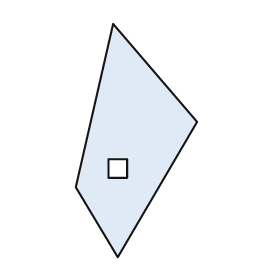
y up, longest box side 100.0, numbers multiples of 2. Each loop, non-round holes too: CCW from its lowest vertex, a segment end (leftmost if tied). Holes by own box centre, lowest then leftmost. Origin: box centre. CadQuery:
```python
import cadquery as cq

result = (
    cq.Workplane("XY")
    .moveTo(-8.0, -50.0)
    .lineTo(26.0, 8.0)
    .lineTo(-10.0, 50.0)
    .lineTo(-26.0, -20.0)
    .close()
    .moveTo(-12.0, -16.0)
    .lineTo(-4.0, -16.0)
    .lineTo(-4.0, -8.0)
    .lineTo(-12.0, -8.0)
    .close()
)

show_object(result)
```